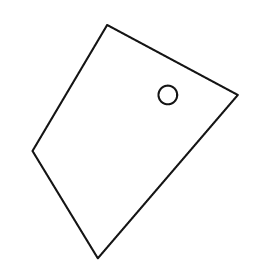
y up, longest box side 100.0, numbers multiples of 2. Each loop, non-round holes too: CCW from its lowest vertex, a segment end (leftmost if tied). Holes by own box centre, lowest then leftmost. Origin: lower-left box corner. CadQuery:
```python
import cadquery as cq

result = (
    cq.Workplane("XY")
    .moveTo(28.0, 0.0)
    .lineTo(88.0, 70.0)
    .lineTo(32.0, 100.0)
    .lineTo(0.0, 46.0)
    .close()
    .moveTo(58.0, 70.0)
    .circle(4.0)
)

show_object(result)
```